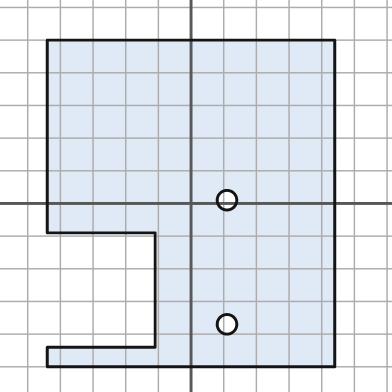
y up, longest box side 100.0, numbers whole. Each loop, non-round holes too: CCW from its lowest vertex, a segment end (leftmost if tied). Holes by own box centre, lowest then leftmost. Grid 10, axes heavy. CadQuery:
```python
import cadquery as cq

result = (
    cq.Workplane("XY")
    .moveTo(-44.0, -50.0)
    .lineTo(44.0, -50.0)
    .lineTo(44.0, 50.0)
    .lineTo(-44.0, 50.0)
    .lineTo(-44.0, -9.0)
    .lineTo(-11.0, -9.0)
    .lineTo(-11.0, -44.0)
    .lineTo(-44.0, -44.0)
    .close()
    .moveTo(11.0, -37.0)
    .circle(3.0)
    .moveTo(11.0, 1.0)
    .circle(3.0)
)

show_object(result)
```